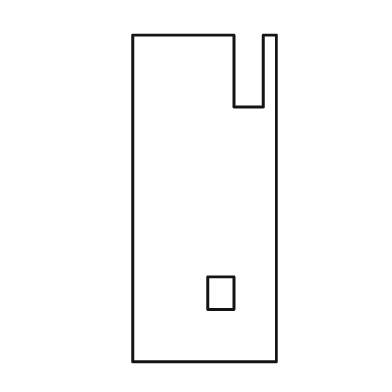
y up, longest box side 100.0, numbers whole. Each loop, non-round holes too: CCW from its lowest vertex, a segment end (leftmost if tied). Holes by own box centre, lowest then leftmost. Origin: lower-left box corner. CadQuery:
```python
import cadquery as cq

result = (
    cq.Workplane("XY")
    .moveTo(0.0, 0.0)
    .lineTo(44.0, 0.0)
    .lineTo(44.0, 100.0)
    .lineTo(40.0, 100.0)
    .lineTo(40.0, 78.0)
    .lineTo(31.0, 78.0)
    .lineTo(31.0, 100.0)
    .lineTo(0.0, 100.0)
    .close()
    .moveTo(23.0, 16.0)
    .lineTo(31.0, 16.0)
    .lineTo(31.0, 26.0)
    .lineTo(23.0, 26.0)
    .close()
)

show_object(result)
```